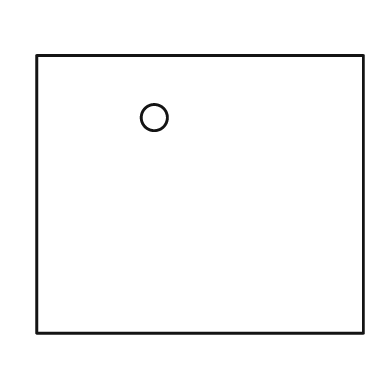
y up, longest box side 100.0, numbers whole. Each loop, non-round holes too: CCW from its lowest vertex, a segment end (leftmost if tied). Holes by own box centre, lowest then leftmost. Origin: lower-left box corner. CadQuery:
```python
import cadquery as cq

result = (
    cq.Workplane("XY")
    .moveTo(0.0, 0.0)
    .lineTo(100.0, 0.0)
    .lineTo(100.0, 85.0)
    .lineTo(0.0, 85.0)
    .close()
    .moveTo(36.0, 66.0)
    .circle(4.0)
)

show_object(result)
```